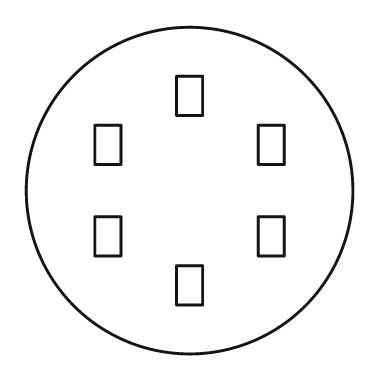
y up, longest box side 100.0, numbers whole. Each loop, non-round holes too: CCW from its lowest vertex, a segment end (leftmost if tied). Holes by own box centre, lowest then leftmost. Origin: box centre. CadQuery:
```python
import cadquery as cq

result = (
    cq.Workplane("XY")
    .moveTo(0.0, 0.0)
    .circle(50.0)
    .moveTo(-4.0, -35.0)
    .lineTo(4.0, -35.0)
    .lineTo(4.0, -23.0)
    .lineTo(-4.0, -23.0)
    .close()
    .moveTo(-29.0, -20.0)
    .lineTo(-21.0, -20.0)
    .lineTo(-21.0, -8.0)
    .lineTo(-29.0, -8.0)
    .close()
    .moveTo(21.0, -20.0)
    .lineTo(29.0, -20.0)
    .lineTo(29.0, -8.0)
    .lineTo(21.0, -8.0)
    .close()
    .moveTo(-29.0, 8.0)
    .lineTo(-21.0, 8.0)
    .lineTo(-21.0, 20.0)
    .lineTo(-29.0, 20.0)
    .close()
    .moveTo(21.0, 8.0)
    .lineTo(29.0, 8.0)
    .lineTo(29.0, 20.0)
    .lineTo(21.0, 20.0)
    .close()
    .moveTo(-4.0, 23.0)
    .lineTo(4.0, 23.0)
    .lineTo(4.0, 35.0)
    .lineTo(-4.0, 35.0)
    .close()
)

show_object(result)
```